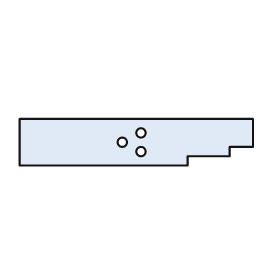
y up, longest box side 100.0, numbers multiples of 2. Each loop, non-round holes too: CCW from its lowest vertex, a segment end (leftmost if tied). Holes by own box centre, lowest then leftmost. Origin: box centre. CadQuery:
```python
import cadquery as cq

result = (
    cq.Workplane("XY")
    .moveTo(-50.0, -10.0)
    .lineTo(22.0, -10.0)
    .lineTo(22.0, -6.0)
    .lineTo(40.0, -6.0)
    .lineTo(40.0, -2.0)
    .lineTo(50.0, -2.0)
    .lineTo(50.0, 10.0)
    .lineTo(-50.0, 10.0)
    .close()
    .moveTo(2.0, -4.0)
    .circle(2.0)
    .moveTo(-6.0, 0.0)
    .circle(2.0)
    .moveTo(2.0, 4.0)
    .circle(2.0)
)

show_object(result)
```